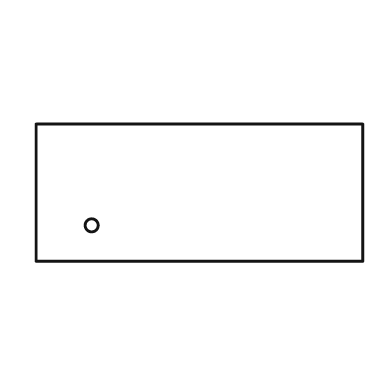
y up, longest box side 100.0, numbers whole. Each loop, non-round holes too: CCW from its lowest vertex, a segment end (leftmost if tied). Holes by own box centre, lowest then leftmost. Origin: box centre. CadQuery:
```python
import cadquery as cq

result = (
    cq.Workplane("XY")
    .moveTo(-50.0, -21.0)
    .lineTo(50.0, -21.0)
    .lineTo(50.0, 21.0)
    .lineTo(-50.0, 21.0)
    .close()
    .moveTo(-33.0, -10.0)
    .circle(2.0)
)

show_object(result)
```